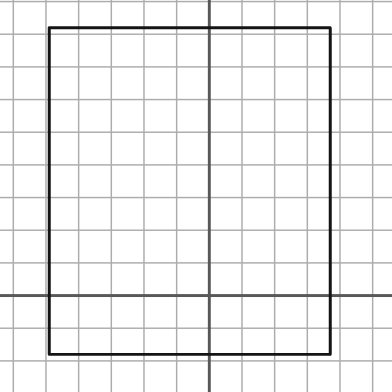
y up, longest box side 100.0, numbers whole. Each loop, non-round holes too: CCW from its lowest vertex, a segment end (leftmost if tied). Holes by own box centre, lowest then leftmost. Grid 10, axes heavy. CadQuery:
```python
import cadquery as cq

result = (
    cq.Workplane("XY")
    .moveTo(-49.0, -18.0)
    .lineTo(37.0, -18.0)
    .lineTo(37.0, 82.0)
    .lineTo(-49.0, 82.0)
    .close()
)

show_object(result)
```